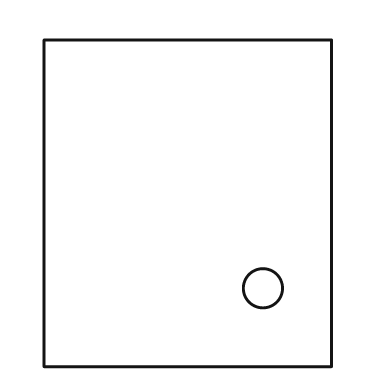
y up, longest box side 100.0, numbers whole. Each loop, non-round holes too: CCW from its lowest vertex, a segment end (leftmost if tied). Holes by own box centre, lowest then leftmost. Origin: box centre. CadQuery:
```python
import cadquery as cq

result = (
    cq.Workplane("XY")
    .moveTo(-44.0, -50.0)
    .lineTo(44.0, -50.0)
    .lineTo(44.0, 50.0)
    .lineTo(-44.0, 50.0)
    .close()
    .moveTo(23.0, -26.0)
    .circle(6.0)
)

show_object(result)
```